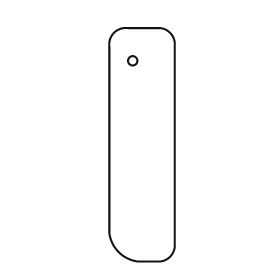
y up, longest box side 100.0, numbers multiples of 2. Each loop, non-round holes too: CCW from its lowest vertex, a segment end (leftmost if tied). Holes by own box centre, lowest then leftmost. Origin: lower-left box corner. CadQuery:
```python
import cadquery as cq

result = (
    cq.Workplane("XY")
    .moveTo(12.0, 0.0)
    .lineTo(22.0, 0.0)
    .threePointArc((26.0, 2.0), (28.0, 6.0))
    .lineTo(28.0, 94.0)
    .threePointArc((26.0, 98.0), (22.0, 100.0))
    .lineTo(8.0, 100.0)
    .threePointArc((2.0, 98.0), (0.0, 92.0))
    .lineTo(0.0, 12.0)
    .threePointArc((4.0, 4.0), (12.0, 0.0))
    .close()
    .moveTo(10.0, 86.0)
    .circle(2.0)
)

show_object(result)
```